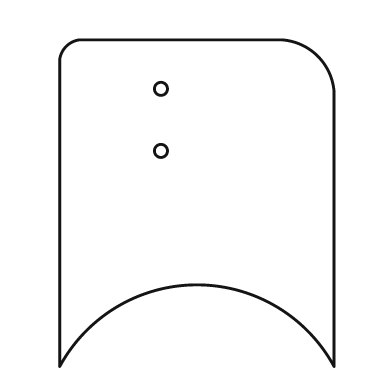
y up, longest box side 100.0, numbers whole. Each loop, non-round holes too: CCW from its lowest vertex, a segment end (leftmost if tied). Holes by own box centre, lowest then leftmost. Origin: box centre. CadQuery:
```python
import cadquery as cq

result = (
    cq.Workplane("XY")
    .moveTo(-42.0, -50.0)
    .threePointArc((0.0, -25.0), (42.0, -50.0))
    .lineTo(42.0, 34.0)
    .threePointArc((37.0, 45.0), (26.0, 50.0))
    .lineTo(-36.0, 50.0)
    .threePointArc((-40.0, 48.0), (-42.0, 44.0))
    .close()
    .moveTo(-11.0, 16.0)
    .circle(2.0)
    .moveTo(-11.0, 35.0)
    .circle(2.0)
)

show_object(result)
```